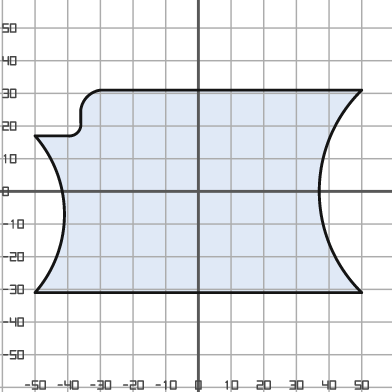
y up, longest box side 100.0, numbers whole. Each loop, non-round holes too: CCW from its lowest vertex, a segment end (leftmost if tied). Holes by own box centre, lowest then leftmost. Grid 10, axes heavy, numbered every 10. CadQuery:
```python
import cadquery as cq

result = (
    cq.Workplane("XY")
    .moveTo(-50.0, -31.0)
    .lineTo(50.0, -31.0)
    .threePointArc((37.0, 0.0), (50.0, 31.0))
    .lineTo(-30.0, 31.0)
    .threePointArc((-34.0, 29.0), (-36.0, 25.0))
    .lineTo(-36.0, 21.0)
    .threePointArc((-37.0, 18.0), (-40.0, 17.0))
    .lineTo(-50.0, 17.0)
    .threePointArc((-41.0, -7.0), (-50.0, -31.0))
    .close()
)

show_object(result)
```